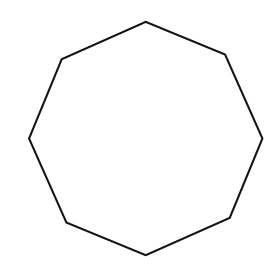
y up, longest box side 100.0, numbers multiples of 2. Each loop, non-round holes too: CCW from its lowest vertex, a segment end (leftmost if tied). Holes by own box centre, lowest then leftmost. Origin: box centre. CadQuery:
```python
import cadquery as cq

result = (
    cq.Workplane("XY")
    .moveTo(0.0, -50.0)
    .lineTo(36.0, -34.0)
    .lineTo(50.0, 0.0)
    .lineTo(34.0, 36.0)
    .lineTo(0.0, 50.0)
    .lineTo(-36.0, 34.0)
    .lineTo(-50.0, 0.0)
    .lineTo(-34.0, -36.0)
    .close()
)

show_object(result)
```